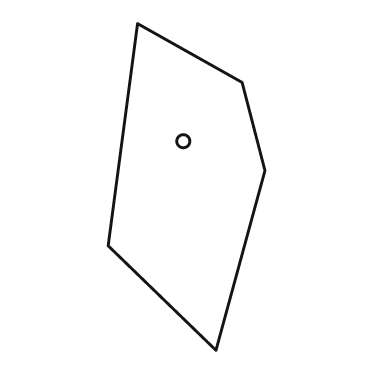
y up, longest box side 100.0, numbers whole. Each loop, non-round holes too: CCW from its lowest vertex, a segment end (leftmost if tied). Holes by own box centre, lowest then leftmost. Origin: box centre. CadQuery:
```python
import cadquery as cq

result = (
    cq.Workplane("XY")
    .moveTo(9.0, -50.0)
    .lineTo(24.0, 5.0)
    .lineTo(17.0, 32.0)
    .lineTo(-15.0, 50.0)
    .lineTo(-24.0, -18.0)
    .close()
    .moveTo(-1.0, 14.0)
    .circle(2.0)
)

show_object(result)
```